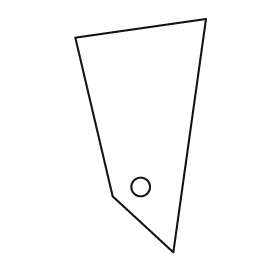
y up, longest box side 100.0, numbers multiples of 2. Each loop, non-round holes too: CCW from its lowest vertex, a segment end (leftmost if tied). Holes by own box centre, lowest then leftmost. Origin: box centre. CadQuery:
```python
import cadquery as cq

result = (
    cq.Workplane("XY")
    .moveTo(14.0, -50.0)
    .lineTo(28.0, 50.0)
    .lineTo(-28.0, 42.0)
    .lineTo(-12.0, -26.0)
    .close()
    .moveTo(0.0, -22.0)
    .circle(4.0)
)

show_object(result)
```